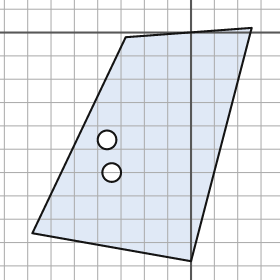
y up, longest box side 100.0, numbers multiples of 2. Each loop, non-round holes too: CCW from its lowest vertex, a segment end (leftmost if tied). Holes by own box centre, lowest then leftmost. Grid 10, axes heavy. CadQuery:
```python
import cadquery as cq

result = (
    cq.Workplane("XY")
    .moveTo(0.0, -98.0)
    .lineTo(26.0, 2.0)
    .lineTo(-28.0, -2.0)
    .lineTo(-68.0, -86.0)
    .close()
    .moveTo(-34.0, -60.0)
    .circle(4.0)
    .moveTo(-36.0, -46.0)
    .circle(4.0)
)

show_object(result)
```